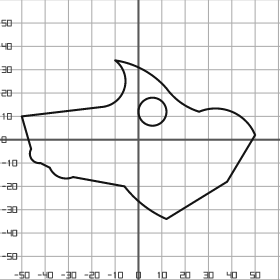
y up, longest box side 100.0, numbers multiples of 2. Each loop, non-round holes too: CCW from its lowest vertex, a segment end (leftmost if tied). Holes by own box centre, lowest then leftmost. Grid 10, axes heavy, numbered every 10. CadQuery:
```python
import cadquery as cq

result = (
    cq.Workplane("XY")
    .moveTo(12.0, -34.0)
    .lineTo(38.0, -18.0)
    .lineTo(50.0, 2.0)
    .threePointArc((40.0, 12.0), (26.0, 12.0))
    .threePointArc((18.0, 16.0), (12.0, 22.0))
    .threePointArc((2.0, 30.0), (-10.0, 34.0))
    .threePointArc((-6.0, 22.0), (-16.0, 14.0))
    .lineTo(-50.0, 10.0)
    .lineTo(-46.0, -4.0)
    .threePointArc((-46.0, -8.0), (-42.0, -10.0))
    .lineTo(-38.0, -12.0)
    .threePointArc((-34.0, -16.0), (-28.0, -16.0))
    .lineTo(-6.0, -20.0)
    .threePointArc((2.0, -28.0), (12.0, -34.0))
    .close()
    .moveTo(6.0, 12.0)
    .circle(6.0)
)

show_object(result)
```